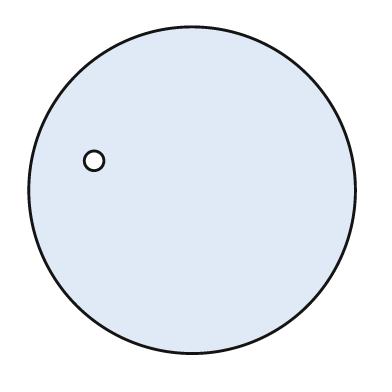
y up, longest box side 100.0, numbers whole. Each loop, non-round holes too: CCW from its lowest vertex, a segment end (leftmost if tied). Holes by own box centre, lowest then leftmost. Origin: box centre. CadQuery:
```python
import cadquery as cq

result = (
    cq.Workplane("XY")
    .moveTo(0.0, 0.0)
    .circle(50.0)
    .moveTo(-30.0, 9.0)
    .circle(3.0)
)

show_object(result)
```